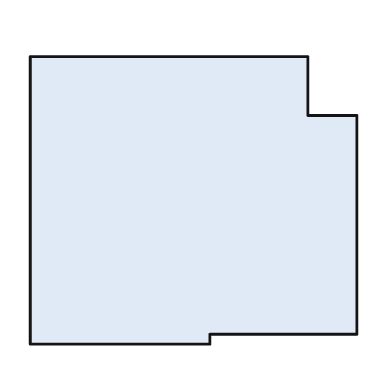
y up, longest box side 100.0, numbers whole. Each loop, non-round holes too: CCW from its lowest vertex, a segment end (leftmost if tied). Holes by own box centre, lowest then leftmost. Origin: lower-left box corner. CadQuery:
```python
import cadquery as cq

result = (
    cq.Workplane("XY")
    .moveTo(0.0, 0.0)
    .lineTo(55.0, 0.0)
    .lineTo(55.0, 3.0)
    .lineTo(100.0, 3.0)
    .lineTo(100.0, 70.0)
    .lineTo(85.0, 70.0)
    .lineTo(85.0, 88.0)
    .lineTo(0.0, 88.0)
    .close()
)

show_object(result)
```